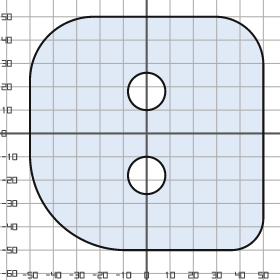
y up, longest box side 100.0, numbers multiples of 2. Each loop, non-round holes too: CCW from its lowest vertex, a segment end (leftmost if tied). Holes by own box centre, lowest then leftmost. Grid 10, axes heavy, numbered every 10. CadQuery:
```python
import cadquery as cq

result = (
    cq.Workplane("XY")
    .moveTo(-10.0, -50.0)
    .lineTo(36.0, -50.0)
    .threePointArc((46.0, -46.0), (50.0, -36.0))
    .lineTo(50.0, 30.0)
    .threePointArc((44.0, 44.0), (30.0, 50.0))
    .lineTo(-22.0, 50.0)
    .threePointArc((-42.0, 42.0), (-50.0, 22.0))
    .lineTo(-50.0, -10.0)
    .threePointArc((-38.0, -38.0), (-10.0, -50.0))
    .close()
    .moveTo(0.0, -18.0)
    .circle(8.0)
    .moveTo(0.0, 18.0)
    .circle(8.0)
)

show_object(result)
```